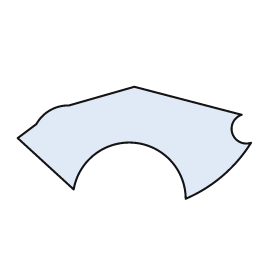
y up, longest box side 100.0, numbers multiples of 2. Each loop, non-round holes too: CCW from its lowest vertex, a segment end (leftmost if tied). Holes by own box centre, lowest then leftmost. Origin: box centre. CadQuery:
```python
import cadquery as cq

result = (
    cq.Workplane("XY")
    .moveTo(22.0, -24.0)
    .threePointArc((38.0, -14.0), (50.0, 0.0))
    .threePointArc((42.0, 4.0), (46.0, 12.0))
    .lineTo(0.0, 24.0)
    .lineTo(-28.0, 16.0)
    .threePointArc((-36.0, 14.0), (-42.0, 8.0))
    .lineTo(-50.0, 2.0)
    .lineTo(-26.0, -20.0)
    .threePointArc((0.0, 0.0), (22.0, -24.0))
    .close()
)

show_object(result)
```